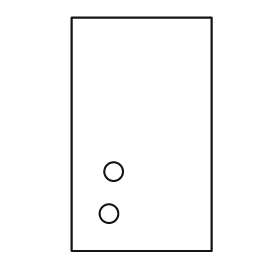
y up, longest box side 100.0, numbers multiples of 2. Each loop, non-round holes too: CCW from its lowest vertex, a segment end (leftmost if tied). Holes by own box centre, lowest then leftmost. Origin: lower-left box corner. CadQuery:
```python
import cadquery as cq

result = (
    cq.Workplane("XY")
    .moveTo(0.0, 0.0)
    .lineTo(60.0, 0.0)
    .lineTo(60.0, 100.0)
    .lineTo(0.0, 100.0)
    .close()
    .moveTo(16.0, 16.0)
    .circle(4.0)
    .moveTo(18.0, 34.0)
    .circle(4.0)
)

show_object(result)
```